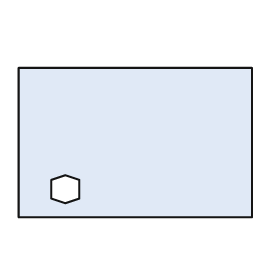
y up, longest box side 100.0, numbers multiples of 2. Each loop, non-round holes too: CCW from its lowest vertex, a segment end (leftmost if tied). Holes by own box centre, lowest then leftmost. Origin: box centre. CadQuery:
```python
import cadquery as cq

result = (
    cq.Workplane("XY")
    .moveTo(-50.0, -32.0)
    .lineTo(50.0, -32.0)
    .lineTo(50.0, 32.0)
    .lineTo(-50.0, 32.0)
    .close()
    .moveTo(-30.0, -26.0)
    .lineTo(-24.0, -24.0)
    .lineTo(-24.0, -16.0)
    .lineTo(-30.0, -14.0)
    .lineTo(-36.0, -16.0)
    .lineTo(-36.0, -24.0)
    .close()
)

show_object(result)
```